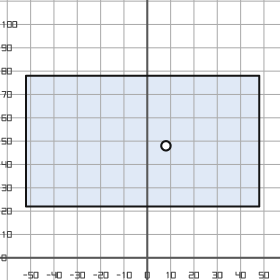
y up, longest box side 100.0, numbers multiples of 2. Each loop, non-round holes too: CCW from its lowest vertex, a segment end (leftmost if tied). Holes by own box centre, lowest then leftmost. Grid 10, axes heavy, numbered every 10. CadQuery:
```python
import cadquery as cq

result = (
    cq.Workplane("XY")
    .moveTo(-52.0, 22.0)
    .lineTo(48.0, 22.0)
    .lineTo(48.0, 78.0)
    .lineTo(-52.0, 78.0)
    .close()
    .moveTo(8.0, 48.0)
    .circle(2.0)
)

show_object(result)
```